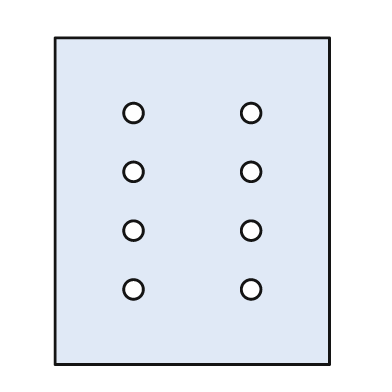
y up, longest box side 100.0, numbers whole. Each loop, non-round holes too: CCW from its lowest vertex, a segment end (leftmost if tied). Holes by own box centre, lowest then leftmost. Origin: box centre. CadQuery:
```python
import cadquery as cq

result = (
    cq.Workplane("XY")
    .moveTo(-42.0, -50.0)
    .lineTo(42.0, -50.0)
    .lineTo(42.0, 50.0)
    .lineTo(-42.0, 50.0)
    .close()
    .moveTo(-18.0, -27.0)
    .circle(3.0)
    .moveTo(18.0, -27.0)
    .circle(3.0)
    .moveTo(-18.0, -9.0)
    .circle(3.0)
    .moveTo(18.0, -9.0)
    .circle(3.0)
    .moveTo(-18.0, 9.0)
    .circle(3.0)
    .moveTo(18.0, 9.0)
    .circle(3.0)
    .moveTo(-18.0, 27.0)
    .circle(3.0)
    .moveTo(18.0, 27.0)
    .circle(3.0)
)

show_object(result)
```